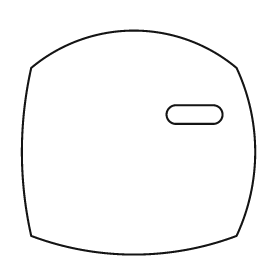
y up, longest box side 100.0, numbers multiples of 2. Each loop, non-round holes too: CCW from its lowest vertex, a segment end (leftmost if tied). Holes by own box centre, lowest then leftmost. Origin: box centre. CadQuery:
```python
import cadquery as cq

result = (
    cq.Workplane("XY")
    .moveTo(-46.0, -40.0)
    .threePointArc((-2.0, -48.0), (42.0, -40.0))
    .threePointArc((50.0, -4.0), (42.0, 32.0))
    .threePointArc((-2.0, 48.0), (-46.0, 32.0))
    .threePointArc((-50.0, -4.0), (-46.0, -40.0))
    .close()
    .moveTo(16.0, 8.0)
    .lineTo(32.0, 8.0)
    .threePointArc((36.0, 12.0), (32.0, 16.0))
    .lineTo(16.0, 16.0)
    .threePointArc((12.0, 12.0), (16.0, 8.0))
    .close()
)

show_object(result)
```